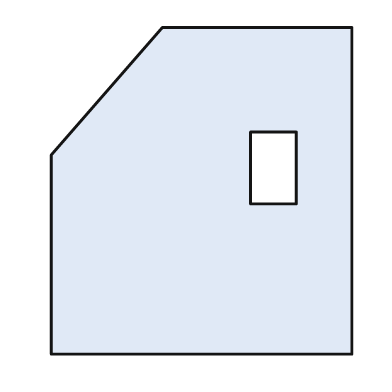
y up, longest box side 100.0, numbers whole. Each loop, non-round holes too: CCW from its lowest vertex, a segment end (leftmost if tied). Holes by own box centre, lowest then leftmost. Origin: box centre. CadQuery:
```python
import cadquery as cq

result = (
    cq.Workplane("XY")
    .moveTo(-46.0, -50.0)
    .lineTo(46.0, -50.0)
    .lineTo(46.0, 50.0)
    .lineTo(-12.0, 50.0)
    .lineTo(-46.0, 11.0)
    .close()
    .moveTo(15.0, -4.0)
    .lineTo(29.0, -4.0)
    .lineTo(29.0, 18.0)
    .lineTo(15.0, 18.0)
    .close()
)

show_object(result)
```